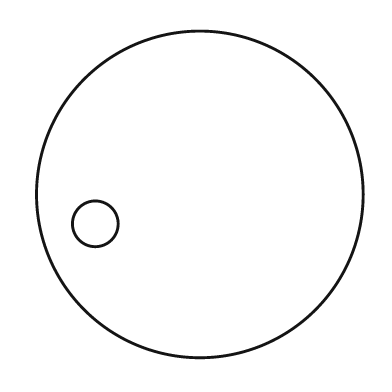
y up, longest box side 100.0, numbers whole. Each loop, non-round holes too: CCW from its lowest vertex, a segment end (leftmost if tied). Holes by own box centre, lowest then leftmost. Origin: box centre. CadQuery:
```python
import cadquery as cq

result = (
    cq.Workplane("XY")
    .moveTo(0.0, 0.0)
    .circle(50.0)
    .moveTo(-32.0, -9.0)
    .circle(7.0)
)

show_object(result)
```